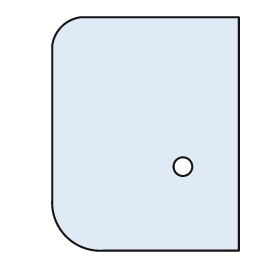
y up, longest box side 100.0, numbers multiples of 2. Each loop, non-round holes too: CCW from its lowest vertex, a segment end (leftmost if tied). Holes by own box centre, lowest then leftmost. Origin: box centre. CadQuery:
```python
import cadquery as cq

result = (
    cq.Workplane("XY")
    .moveTo(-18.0, -50.0)
    .lineTo(40.0, -50.0)
    .lineTo(40.0, 50.0)
    .lineTo(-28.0, 50.0)
    .threePointArc((-36.0, 46.0), (-40.0, 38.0))
    .lineTo(-40.0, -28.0)
    .threePointArc((-34.0, -44.0), (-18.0, -50.0))
    .close()
    .moveTo(16.0, -14.0)
    .circle(4.0)
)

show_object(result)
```